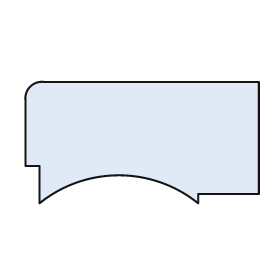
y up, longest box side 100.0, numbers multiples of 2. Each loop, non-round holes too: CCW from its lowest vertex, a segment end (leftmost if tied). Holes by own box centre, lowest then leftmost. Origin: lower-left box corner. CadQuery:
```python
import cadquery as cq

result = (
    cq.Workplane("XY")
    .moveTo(6.0, 0.0)
    .threePointArc((40.0, 12.0), (74.0, 0.0))
    .lineTo(74.0, 4.0)
    .lineTo(100.0, 4.0)
    .lineTo(100.0, 52.0)
    .lineTo(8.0, 52.0)
    .threePointArc((2.0, 50.0), (0.0, 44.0))
    .lineTo(0.0, 16.0)
    .lineTo(6.0, 16.0)
    .close()
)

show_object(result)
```